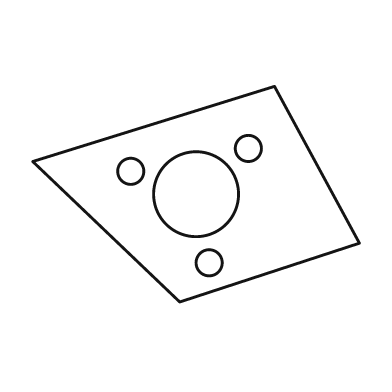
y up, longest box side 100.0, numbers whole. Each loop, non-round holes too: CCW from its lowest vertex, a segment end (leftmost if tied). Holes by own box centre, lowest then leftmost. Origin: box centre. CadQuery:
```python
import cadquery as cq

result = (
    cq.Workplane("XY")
    .moveTo(-5.0, -33.0)
    .lineTo(50.0, -15.0)
    .lineTo(24.0, 33.0)
    .lineTo(-50.0, 10.0)
    .close()
    .moveTo(4.0, -21.0)
    .circle(4.0)
    .moveTo(0.0, 0.0)
    .circle(13.0)
    .moveTo(-20.0, 7.0)
    .circle(4.0)
    .moveTo(16.0, 14.0)
    .circle(4.0)
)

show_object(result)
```